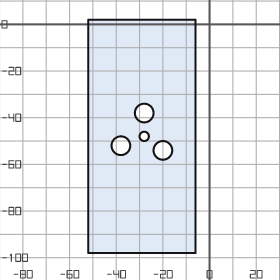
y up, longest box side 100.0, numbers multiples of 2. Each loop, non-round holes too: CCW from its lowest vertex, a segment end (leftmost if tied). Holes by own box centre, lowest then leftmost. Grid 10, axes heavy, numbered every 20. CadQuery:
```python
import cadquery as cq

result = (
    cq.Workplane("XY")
    .moveTo(-52.0, -98.0)
    .lineTo(-6.0, -98.0)
    .lineTo(-6.0, 2.0)
    .lineTo(-52.0, 2.0)
    .close()
    .moveTo(-20.0, -54.0)
    .circle(4.0)
    .moveTo(-38.0, -52.0)
    .circle(4.0)
    .moveTo(-28.0, -48.0)
    .circle(2.0)
    .moveTo(-28.0, -38.0)
    .circle(4.0)
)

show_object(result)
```